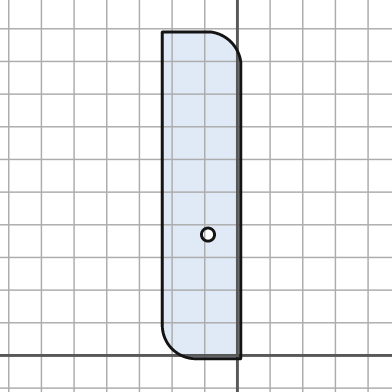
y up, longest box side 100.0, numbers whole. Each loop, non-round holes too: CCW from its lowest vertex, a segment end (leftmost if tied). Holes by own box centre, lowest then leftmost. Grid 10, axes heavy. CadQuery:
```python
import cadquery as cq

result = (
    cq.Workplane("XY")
    .moveTo(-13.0, -1.0)
    .lineTo(1.0, -1.0)
    .lineTo(1.0, 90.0)
    .threePointArc((-2.0, 96.0), (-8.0, 99.0))
    .lineTo(-23.0, 99.0)
    .lineTo(-23.0, 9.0)
    .threePointArc((-20.0, 2.0), (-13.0, -1.0))
    .close()
    .moveTo(-9.0, 37.0)
    .circle(2.0)
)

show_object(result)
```